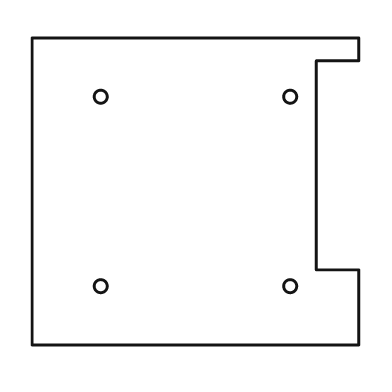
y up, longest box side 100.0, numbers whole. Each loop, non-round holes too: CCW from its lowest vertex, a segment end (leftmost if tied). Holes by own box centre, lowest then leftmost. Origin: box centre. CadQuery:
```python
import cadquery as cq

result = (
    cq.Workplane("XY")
    .moveTo(-50.0, -47.0)
    .lineTo(50.0, -47.0)
    .lineTo(50.0, -24.0)
    .lineTo(37.0, -24.0)
    .lineTo(37.0, 40.0)
    .lineTo(50.0, 40.0)
    .lineTo(50.0, 47.0)
    .lineTo(-50.0, 47.0)
    .close()
    .moveTo(-29.0, -29.0)
    .circle(2.0)
    .moveTo(29.0, -29.0)
    .circle(2.0)
    .moveTo(-29.0, 29.0)
    .circle(2.0)
    .moveTo(29.0, 29.0)
    .circle(2.0)
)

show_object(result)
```